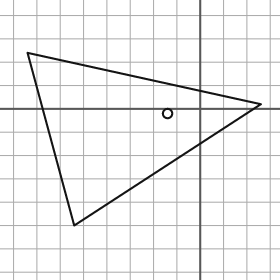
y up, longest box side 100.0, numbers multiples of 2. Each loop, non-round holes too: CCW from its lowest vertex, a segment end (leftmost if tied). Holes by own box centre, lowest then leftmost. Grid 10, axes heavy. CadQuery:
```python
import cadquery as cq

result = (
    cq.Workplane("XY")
    .moveTo(-54.0, -50.0)
    .lineTo(26.0, 2.0)
    .lineTo(-74.0, 24.0)
    .close()
    .moveTo(-14.0, -2.0)
    .circle(2.0)
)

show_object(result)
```